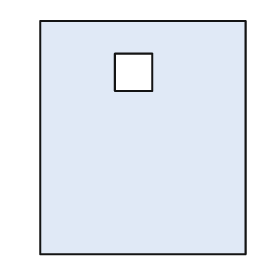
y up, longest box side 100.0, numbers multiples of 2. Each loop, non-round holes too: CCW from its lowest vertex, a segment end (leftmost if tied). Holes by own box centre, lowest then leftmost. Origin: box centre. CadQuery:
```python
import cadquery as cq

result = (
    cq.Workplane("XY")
    .moveTo(-44.0, -50.0)
    .lineTo(44.0, -50.0)
    .lineTo(44.0, 50.0)
    .lineTo(-44.0, 50.0)
    .close()
    .moveTo(-12.0, 20.0)
    .lineTo(4.0, 20.0)
    .lineTo(4.0, 36.0)
    .lineTo(-12.0, 36.0)
    .close()
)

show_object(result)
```